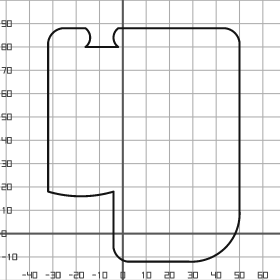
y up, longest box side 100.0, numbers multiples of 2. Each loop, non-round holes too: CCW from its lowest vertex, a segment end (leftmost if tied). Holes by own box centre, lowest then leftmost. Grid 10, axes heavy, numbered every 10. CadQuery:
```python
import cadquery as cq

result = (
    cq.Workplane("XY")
    .moveTo(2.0, -12.0)
    .lineTo(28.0, -12.0)
    .threePointArc((44.0, -6.0), (50.0, 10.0))
    .lineTo(50.0, 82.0)
    .threePointArc((48.0, 86.0), (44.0, 88.0))
    .lineTo(-2.0, 88.0)
    .threePointArc((-4.0, 84.0), (-2.0, 80.0))
    .lineTo(-16.0, 80.0)
    .threePointArc((-14.0, 84.0), (-16.0, 88.0))
    .lineTo(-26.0, 88.0)
    .threePointArc((-30.0, 86.0), (-32.0, 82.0))
    .lineTo(-32.0, 18.0)
    .threePointArc((-18.0, 16.0), (-4.0, 18.0))
    .lineTo(-4.0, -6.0)
    .threePointArc((-2.0, -10.0), (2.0, -12.0))
    .close()
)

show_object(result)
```